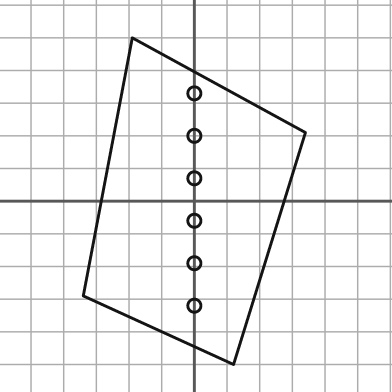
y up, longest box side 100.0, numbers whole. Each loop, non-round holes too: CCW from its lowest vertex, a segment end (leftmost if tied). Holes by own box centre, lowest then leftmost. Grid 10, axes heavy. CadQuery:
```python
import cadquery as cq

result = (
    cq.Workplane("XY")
    .moveTo(12.0, -50.0)
    .lineTo(34.0, 21.0)
    .lineTo(-19.0, 50.0)
    .lineTo(-34.0, -29.0)
    .close()
    .moveTo(0.0, -32.0)
    .circle(2.0)
    .moveTo(0.0, -19.0)
    .circle(2.0)
    .moveTo(0.0, -6.0)
    .circle(2.0)
    .moveTo(0.0, 7.0)
    .circle(2.0)
    .moveTo(0.0, 20.0)
    .circle(2.0)
    .moveTo(0.0, 33.0)
    .circle(2.0)
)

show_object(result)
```